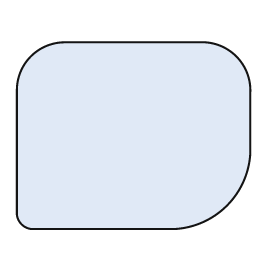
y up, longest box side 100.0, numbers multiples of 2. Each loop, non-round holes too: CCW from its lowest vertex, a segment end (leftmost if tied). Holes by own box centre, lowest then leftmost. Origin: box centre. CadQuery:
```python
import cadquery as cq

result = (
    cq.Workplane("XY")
    .moveTo(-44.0, -40.0)
    .lineTo(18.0, -40.0)
    .threePointArc((40.0, -30.0), (50.0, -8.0))
    .lineTo(50.0, 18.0)
    .threePointArc((44.0, 34.0), (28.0, 40.0))
    .lineTo(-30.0, 40.0)
    .threePointArc((-44.0, 34.0), (-50.0, 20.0))
    .lineTo(-50.0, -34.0)
    .threePointArc((-48.0, -38.0), (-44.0, -40.0))
    .close()
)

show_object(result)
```